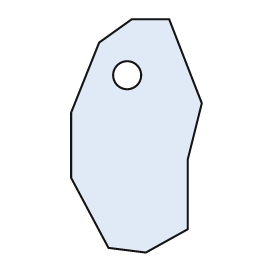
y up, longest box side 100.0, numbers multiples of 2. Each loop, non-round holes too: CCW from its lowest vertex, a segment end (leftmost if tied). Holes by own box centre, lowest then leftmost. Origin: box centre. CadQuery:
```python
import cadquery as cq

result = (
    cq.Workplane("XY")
    .moveTo(4.0, -50.0)
    .lineTo(22.0, -40.0)
    .lineTo(22.0, -10.0)
    .lineTo(28.0, 14.0)
    .lineTo(14.0, 50.0)
    .lineTo(-2.0, 50.0)
    .lineTo(-16.0, 40.0)
    .lineTo(-28.0, 10.0)
    .lineTo(-28.0, -18.0)
    .lineTo(-12.0, -48.0)
    .close()
    .moveTo(-4.0, 26.0)
    .circle(6.0)
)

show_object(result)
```